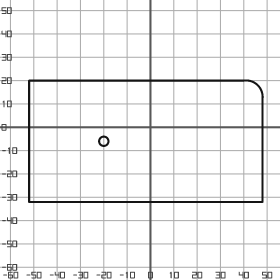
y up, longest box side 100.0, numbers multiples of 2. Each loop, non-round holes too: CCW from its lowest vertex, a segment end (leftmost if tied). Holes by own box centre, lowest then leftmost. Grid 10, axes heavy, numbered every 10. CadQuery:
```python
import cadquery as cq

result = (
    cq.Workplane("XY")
    .moveTo(-52.0, -32.0)
    .lineTo(48.0, -32.0)
    .lineTo(48.0, 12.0)
    .threePointArc((46.0, 18.0), (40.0, 20.0))
    .lineTo(-52.0, 20.0)
    .close()
    .moveTo(-20.0, -6.0)
    .circle(2.0)
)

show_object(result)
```